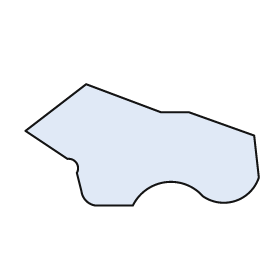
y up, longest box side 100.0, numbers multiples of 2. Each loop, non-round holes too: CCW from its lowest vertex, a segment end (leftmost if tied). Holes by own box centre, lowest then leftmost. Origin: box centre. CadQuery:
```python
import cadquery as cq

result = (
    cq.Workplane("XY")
    .moveTo(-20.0, -26.0)
    .lineTo(-4.0, -26.0)
    .threePointArc((10.0, -16.0), (26.0, -22.0))
    .threePointArc((40.0, -24.0), (50.0, -14.0))
    .lineTo(48.0, 4.0)
    .lineTo(20.0, 14.0)
    .lineTo(8.0, 14.0)
    .lineTo(-24.0, 26.0)
    .lineTo(-50.0, 6.0)
    .lineTo(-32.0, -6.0)
    .threePointArc((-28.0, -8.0), (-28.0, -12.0))
    .lineTo(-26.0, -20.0)
    .threePointArc((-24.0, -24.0), (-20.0, -26.0))
    .close()
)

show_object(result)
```